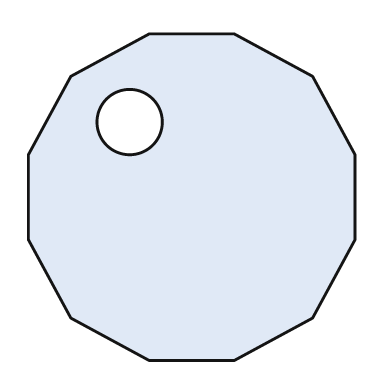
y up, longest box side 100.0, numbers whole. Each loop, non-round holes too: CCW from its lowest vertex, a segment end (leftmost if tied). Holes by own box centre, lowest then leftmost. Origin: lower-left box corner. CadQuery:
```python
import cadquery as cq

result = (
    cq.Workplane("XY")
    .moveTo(37.0, 0.0)
    .lineTo(63.0, 0.0)
    .lineTo(87.0, 13.0)
    .lineTo(100.0, 37.0)
    .lineTo(100.0, 63.0)
    .lineTo(87.0, 87.0)
    .lineTo(63.0, 100.0)
    .lineTo(37.0, 100.0)
    .lineTo(13.0, 87.0)
    .lineTo(0.0, 63.0)
    .lineTo(0.0, 37.0)
    .lineTo(13.0, 13.0)
    .close()
    .moveTo(31.0, 73.0)
    .circle(10.0)
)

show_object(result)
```